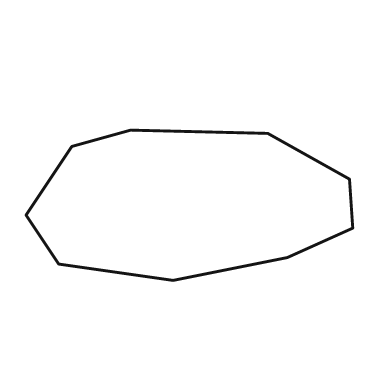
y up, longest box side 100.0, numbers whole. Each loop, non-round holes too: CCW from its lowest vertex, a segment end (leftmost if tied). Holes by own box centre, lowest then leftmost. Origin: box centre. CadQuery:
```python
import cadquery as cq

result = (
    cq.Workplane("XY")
    .moveTo(-5.0, -23.0)
    .lineTo(30.0, -16.0)
    .lineTo(50.0, -7.0)
    .lineTo(49.0, 8.0)
    .lineTo(24.0, 22.0)
    .lineTo(-18.0, 23.0)
    .lineTo(-36.0, 18.0)
    .lineTo(-50.0, -3.0)
    .lineTo(-40.0, -18.0)
    .close()
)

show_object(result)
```